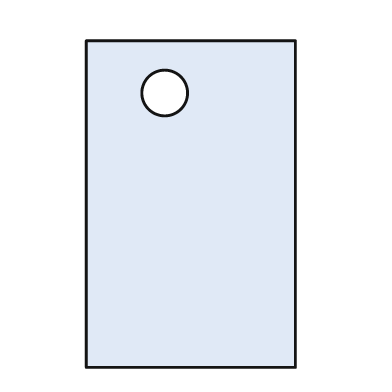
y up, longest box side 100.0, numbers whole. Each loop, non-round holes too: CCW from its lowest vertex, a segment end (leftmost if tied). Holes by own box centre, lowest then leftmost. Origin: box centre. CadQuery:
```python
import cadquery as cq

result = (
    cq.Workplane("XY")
    .moveTo(-32.0, -50.0)
    .lineTo(32.0, -50.0)
    .lineTo(32.0, 50.0)
    .lineTo(-32.0, 50.0)
    .close()
    .moveTo(-8.0, 34.0)
    .circle(7.0)
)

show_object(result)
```